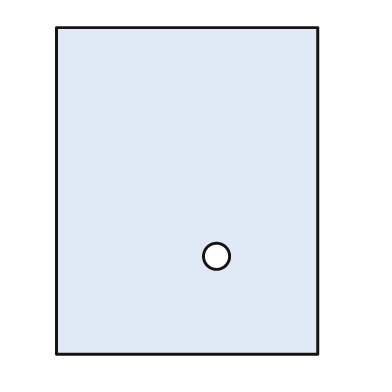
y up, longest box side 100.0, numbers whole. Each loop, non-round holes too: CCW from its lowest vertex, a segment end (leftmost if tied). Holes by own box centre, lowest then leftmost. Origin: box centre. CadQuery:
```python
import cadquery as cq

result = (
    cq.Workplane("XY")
    .moveTo(-40.0, -50.0)
    .lineTo(40.0, -50.0)
    .lineTo(40.0, 50.0)
    .lineTo(-40.0, 50.0)
    .close()
    .moveTo(9.0, -20.0)
    .circle(4.0)
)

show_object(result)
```